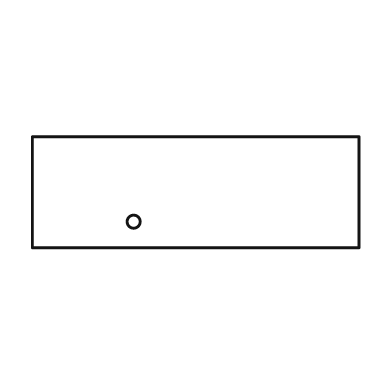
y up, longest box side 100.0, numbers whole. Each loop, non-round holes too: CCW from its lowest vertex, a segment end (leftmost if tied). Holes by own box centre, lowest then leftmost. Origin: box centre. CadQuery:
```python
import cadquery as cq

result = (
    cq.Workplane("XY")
    .moveTo(-50.0, -17.0)
    .lineTo(50.0, -17.0)
    .lineTo(50.0, 17.0)
    .lineTo(-50.0, 17.0)
    .close()
    .moveTo(-19.0, -9.0)
    .circle(2.0)
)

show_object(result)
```